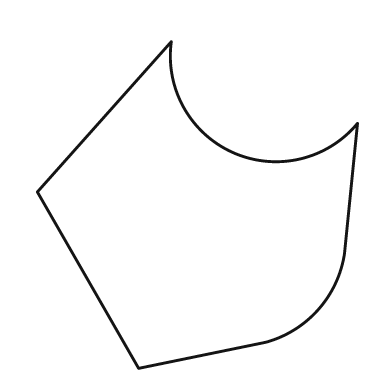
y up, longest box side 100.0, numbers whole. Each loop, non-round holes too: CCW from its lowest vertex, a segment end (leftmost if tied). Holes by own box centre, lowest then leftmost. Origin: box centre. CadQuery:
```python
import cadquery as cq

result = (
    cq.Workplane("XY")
    .moveTo(-18.0, -50.0)
    .lineTo(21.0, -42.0)
    .threePointArc((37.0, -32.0), (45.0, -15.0))
    .lineTo(49.0, 25.0)
    .threePointArc((11.0, 16.0), (-8.0, 50.0))
    .lineTo(-49.0, 4.0)
    .close()
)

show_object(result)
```